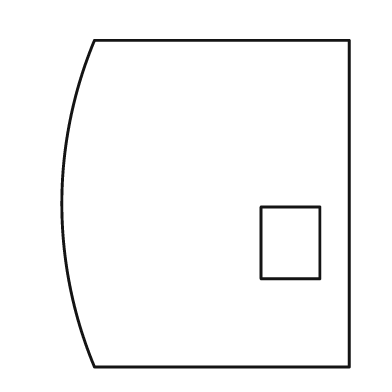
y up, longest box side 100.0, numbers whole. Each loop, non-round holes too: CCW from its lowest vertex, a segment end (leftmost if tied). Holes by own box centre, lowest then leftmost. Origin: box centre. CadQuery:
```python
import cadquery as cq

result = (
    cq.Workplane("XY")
    .moveTo(-34.0, -50.0)
    .lineTo(44.0, -50.0)
    .lineTo(44.0, 50.0)
    .lineTo(-34.0, 50.0)
    .threePointArc((-44.0, 0.0), (-34.0, -50.0))
    .close()
    .moveTo(17.0, -23.0)
    .lineTo(35.0, -23.0)
    .lineTo(35.0, -1.0)
    .lineTo(17.0, -1.0)
    .close()
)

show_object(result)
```